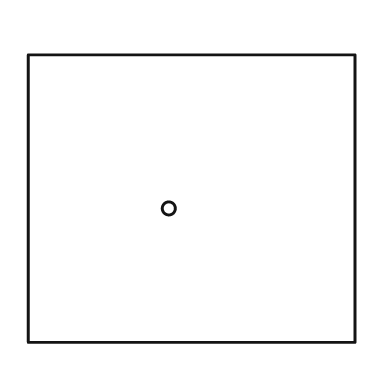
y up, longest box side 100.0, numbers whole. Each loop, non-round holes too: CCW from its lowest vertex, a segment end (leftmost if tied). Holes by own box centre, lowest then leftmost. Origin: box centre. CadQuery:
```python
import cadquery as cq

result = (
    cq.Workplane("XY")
    .moveTo(-50.0, -44.0)
    .lineTo(50.0, -44.0)
    .lineTo(50.0, 44.0)
    .lineTo(-50.0, 44.0)
    .close()
    .moveTo(-7.0, -3.0)
    .circle(2.0)
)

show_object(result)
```